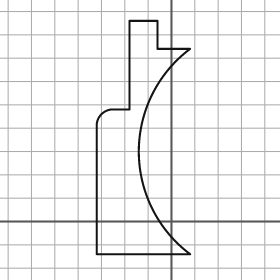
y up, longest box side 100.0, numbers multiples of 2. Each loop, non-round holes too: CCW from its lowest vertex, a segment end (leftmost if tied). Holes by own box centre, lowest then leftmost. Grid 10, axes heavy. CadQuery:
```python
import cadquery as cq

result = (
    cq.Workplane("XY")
    .moveTo(-32.0, -14.0)
    .lineTo(8.0, -14.0)
    .threePointArc((-14.0, 30.0), (8.0, 74.0))
    .lineTo(-6.0, 74.0)
    .lineTo(-6.0, 86.0)
    .lineTo(-18.0, 86.0)
    .lineTo(-18.0, 48.0)
    .lineTo(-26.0, 48.0)
    .threePointArc((-30.0, 46.0), (-32.0, 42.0))
    .close()
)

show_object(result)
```